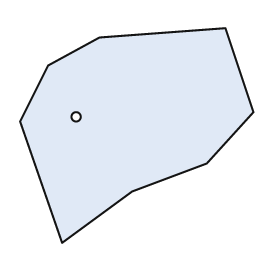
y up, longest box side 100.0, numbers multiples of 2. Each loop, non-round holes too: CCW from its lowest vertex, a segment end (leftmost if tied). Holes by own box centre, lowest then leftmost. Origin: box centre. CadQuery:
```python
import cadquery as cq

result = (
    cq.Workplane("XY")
    .moveTo(-32.0, -46.0)
    .lineTo(-2.0, -24.0)
    .lineTo(30.0, -12.0)
    .lineTo(50.0, 10.0)
    .lineTo(38.0, 46.0)
    .lineTo(-16.0, 42.0)
    .lineTo(-38.0, 30.0)
    .lineTo(-50.0, 6.0)
    .close()
    .moveTo(-26.0, 8.0)
    .circle(2.0)
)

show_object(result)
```